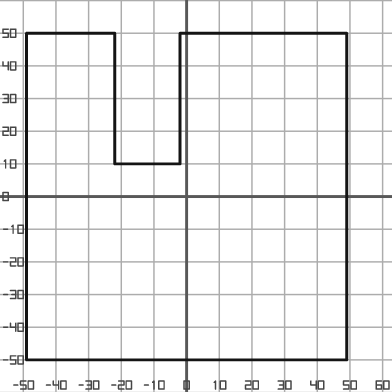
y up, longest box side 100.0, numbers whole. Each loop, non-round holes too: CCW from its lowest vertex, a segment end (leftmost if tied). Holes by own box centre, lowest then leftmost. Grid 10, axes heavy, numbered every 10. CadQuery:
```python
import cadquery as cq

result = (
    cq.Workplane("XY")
    .moveTo(-49.0, -50.0)
    .lineTo(49.0, -50.0)
    .lineTo(49.0, 50.0)
    .lineTo(-2.0, 50.0)
    .lineTo(-2.0, 10.0)
    .lineTo(-22.0, 10.0)
    .lineTo(-22.0, 50.0)
    .lineTo(-49.0, 50.0)
    .close()
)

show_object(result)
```